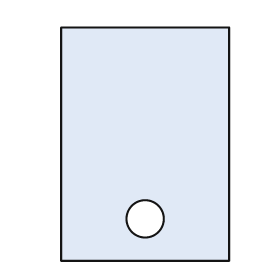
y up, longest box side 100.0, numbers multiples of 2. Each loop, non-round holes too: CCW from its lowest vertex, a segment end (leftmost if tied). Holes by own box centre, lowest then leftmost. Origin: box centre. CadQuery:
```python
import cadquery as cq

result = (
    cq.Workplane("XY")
    .moveTo(-36.0, -50.0)
    .lineTo(36.0, -50.0)
    .lineTo(36.0, 50.0)
    .lineTo(-36.0, 50.0)
    .close()
    .moveTo(0.0, -32.0)
    .circle(8.0)
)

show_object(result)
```